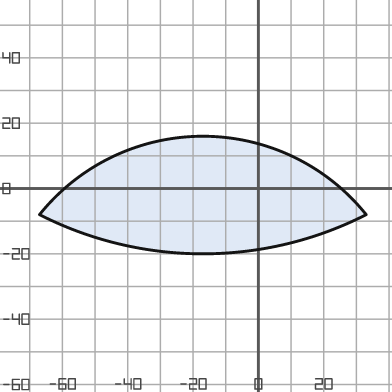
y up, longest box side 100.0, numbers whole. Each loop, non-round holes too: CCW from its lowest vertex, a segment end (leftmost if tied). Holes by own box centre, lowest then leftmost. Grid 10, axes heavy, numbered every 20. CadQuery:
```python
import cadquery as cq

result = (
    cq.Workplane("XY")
    .moveTo(-67.0, -8.0)
    .threePointArc((-17.0, -20.0), (33.0, -8.0))
    .threePointArc((-17.0, 16.0), (-67.0, -8.0))
    .close()
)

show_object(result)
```